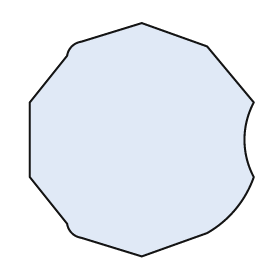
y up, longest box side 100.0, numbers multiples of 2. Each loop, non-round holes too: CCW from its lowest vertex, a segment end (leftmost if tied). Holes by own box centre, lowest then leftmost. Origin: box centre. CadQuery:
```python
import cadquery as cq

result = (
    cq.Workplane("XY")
    .moveTo(0.0, -50.0)
    .lineTo(28.0, -40.0)
    .threePointArc((40.0, -30.0), (48.0, -16.0))
    .threePointArc((44.0, 0.0), (48.0, 16.0))
    .lineTo(28.0, 40.0)
    .lineTo(0.0, 50.0)
    .lineTo(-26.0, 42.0)
    .threePointArc((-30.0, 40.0), (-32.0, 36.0))
    .lineTo(-48.0, 16.0)
    .lineTo(-48.0, -16.0)
    .lineTo(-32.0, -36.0)
    .threePointArc((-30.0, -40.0), (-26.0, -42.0))
    .close()
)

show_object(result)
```